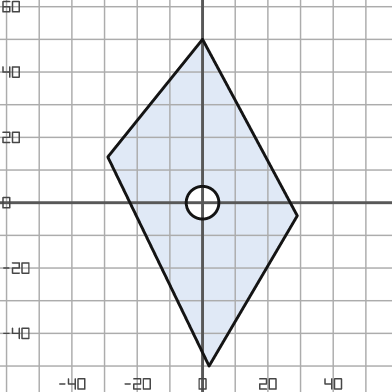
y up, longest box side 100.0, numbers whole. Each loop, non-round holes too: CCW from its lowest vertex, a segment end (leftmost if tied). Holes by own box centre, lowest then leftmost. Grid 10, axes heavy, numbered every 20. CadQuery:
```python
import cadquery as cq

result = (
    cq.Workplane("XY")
    .moveTo(2.0, -50.0)
    .lineTo(29.0, -4.0)
    .lineTo(0.0, 50.0)
    .lineTo(-29.0, 14.0)
    .close()
    .moveTo(0.0, 0.0)
    .circle(5.0)
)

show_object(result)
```